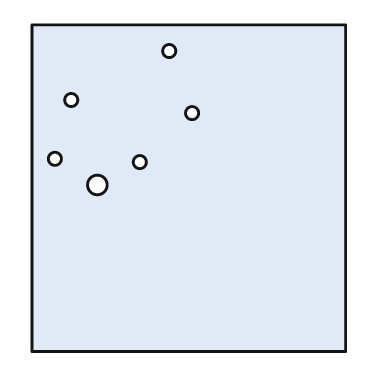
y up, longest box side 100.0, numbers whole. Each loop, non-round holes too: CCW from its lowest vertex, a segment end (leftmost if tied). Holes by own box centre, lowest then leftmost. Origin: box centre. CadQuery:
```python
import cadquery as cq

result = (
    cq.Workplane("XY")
    .moveTo(-48.0, -50.0)
    .lineTo(48.0, -50.0)
    .lineTo(48.0, 50.0)
    .lineTo(-48.0, 50.0)
    .close()
    .moveTo(-28.0, 1.0)
    .circle(3.0)
    .moveTo(-15.0, 8.0)
    .circle(2.0)
    .moveTo(-41.0, 9.0)
    .circle(2.0)
    .moveTo(1.0, 23.0)
    .circle(2.0)
    .moveTo(-36.0, 27.0)
    .circle(2.0)
    .moveTo(-6.0, 42.0)
    .circle(2.0)
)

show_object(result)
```